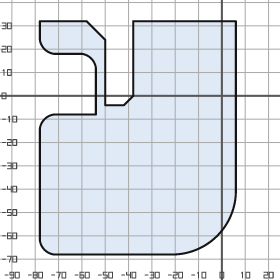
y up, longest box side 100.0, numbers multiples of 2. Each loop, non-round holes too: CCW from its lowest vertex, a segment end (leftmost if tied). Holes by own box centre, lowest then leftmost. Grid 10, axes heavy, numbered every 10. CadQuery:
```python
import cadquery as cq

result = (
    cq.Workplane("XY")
    .moveTo(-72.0, -68.0)
    .lineTo(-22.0, -68.0)
    .threePointArc((-2.0, -60.0), (6.0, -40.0))
    .lineTo(6.0, 32.0)
    .lineTo(-38.0, 32.0)
    .lineTo(-38.0, 0.0)
    .lineTo(-42.0, -4.0)
    .lineTo(-50.0, -4.0)
    .lineTo(-50.0, 24.0)
    .lineTo(-58.0, 32.0)
    .lineTo(-78.0, 32.0)
    .lineTo(-78.0, 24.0)
    .threePointArc((-76.0, 20.0), (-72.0, 18.0))
    .lineTo(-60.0, 18.0)
    .threePointArc((-56.0, 16.0), (-54.0, 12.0))
    .lineTo(-54.0, -8.0)
    .lineTo(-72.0, -8.0)
    .threePointArc((-76.0, -10.0), (-78.0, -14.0))
    .lineTo(-78.0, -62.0)
    .threePointArc((-76.0, -66.0), (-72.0, -68.0))
    .close()
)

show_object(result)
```